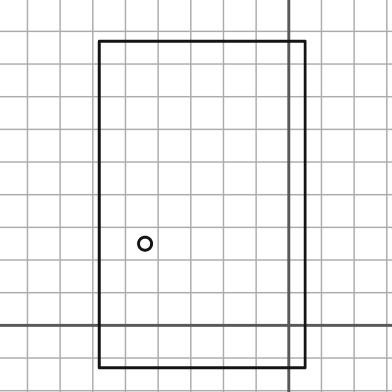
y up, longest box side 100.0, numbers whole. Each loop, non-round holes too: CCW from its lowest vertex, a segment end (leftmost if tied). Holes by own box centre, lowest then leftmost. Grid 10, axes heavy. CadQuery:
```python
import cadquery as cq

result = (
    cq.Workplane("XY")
    .moveTo(-58.0, -13.0)
    .lineTo(5.0, -13.0)
    .lineTo(5.0, 87.0)
    .lineTo(-58.0, 87.0)
    .close()
    .moveTo(-44.0, 25.0)
    .circle(2.0)
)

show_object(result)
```